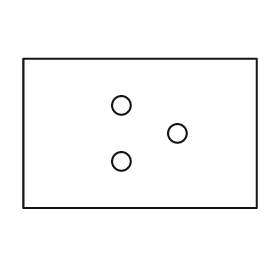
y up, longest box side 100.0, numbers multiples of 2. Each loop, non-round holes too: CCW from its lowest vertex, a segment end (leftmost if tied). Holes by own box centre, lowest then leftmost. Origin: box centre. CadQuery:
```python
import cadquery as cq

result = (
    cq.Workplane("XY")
    .moveTo(-50.0, -32.0)
    .lineTo(50.0, -32.0)
    .lineTo(50.0, 32.0)
    .lineTo(-50.0, 32.0)
    .close()
    .moveTo(-8.0, -12.0)
    .circle(4.0)
    .moveTo(16.0, 0.0)
    .circle(4.0)
    .moveTo(-8.0, 12.0)
    .circle(4.0)
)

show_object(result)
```